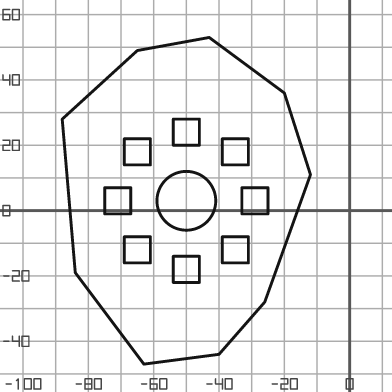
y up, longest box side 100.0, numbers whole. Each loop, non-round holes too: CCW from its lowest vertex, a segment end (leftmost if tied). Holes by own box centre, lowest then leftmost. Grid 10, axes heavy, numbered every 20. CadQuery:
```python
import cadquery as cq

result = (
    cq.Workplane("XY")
    .moveTo(-63.0, -47.0)
    .lineTo(-40.0, -44.0)
    .lineTo(-26.0, -28.0)
    .lineTo(-12.0, 11.0)
    .lineTo(-20.0, 36.0)
    .lineTo(-43.0, 53.0)
    .lineTo(-65.0, 49.0)
    .lineTo(-88.0, 28.0)
    .lineTo(-84.0, -19.0)
    .close()
    .moveTo(-54.0, -22.0)
    .lineTo(-46.0, -22.0)
    .lineTo(-46.0, -14.0)
    .lineTo(-54.0, -14.0)
    .close()
    .moveTo(-69.0, -16.0)
    .lineTo(-61.0, -16.0)
    .lineTo(-61.0, -8.0)
    .lineTo(-69.0, -8.0)
    .close()
    .moveTo(-39.0, -16.0)
    .lineTo(-31.0, -16.0)
    .lineTo(-31.0, -8.0)
    .lineTo(-39.0, -8.0)
    .close()
    .moveTo(-75.0, -1.0)
    .lineTo(-67.0, -1.0)
    .lineTo(-67.0, 7.0)
    .lineTo(-75.0, 7.0)
    .close()
    .moveTo(-50.0, 3.0)
    .circle(9.0)
    .moveTo(-33.0, -1.0)
    .lineTo(-25.0, -1.0)
    .lineTo(-25.0, 7.0)
    .lineTo(-33.0, 7.0)
    .close()
    .moveTo(-69.0, 14.0)
    .lineTo(-61.0, 14.0)
    .lineTo(-61.0, 22.0)
    .lineTo(-69.0, 22.0)
    .close()
    .moveTo(-39.0, 14.0)
    .lineTo(-31.0, 14.0)
    .lineTo(-31.0, 22.0)
    .lineTo(-39.0, 22.0)
    .close()
    .moveTo(-54.0, 20.0)
    .lineTo(-46.0, 20.0)
    .lineTo(-46.0, 28.0)
    .lineTo(-54.0, 28.0)
    .close()
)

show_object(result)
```